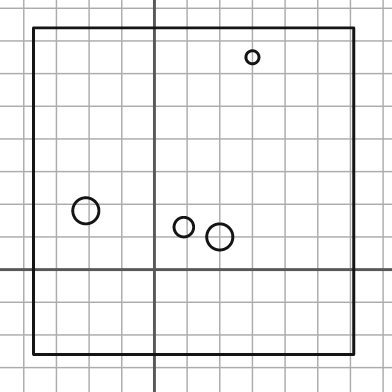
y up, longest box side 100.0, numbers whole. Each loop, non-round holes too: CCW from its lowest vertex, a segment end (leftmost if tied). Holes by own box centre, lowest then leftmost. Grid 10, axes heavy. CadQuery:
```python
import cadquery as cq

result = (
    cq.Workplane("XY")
    .moveTo(-37.0, -26.0)
    .lineTo(61.0, -26.0)
    .lineTo(61.0, 74.0)
    .lineTo(-37.0, 74.0)
    .close()
    .moveTo(20.0, 10.0)
    .circle(4.0)
    .moveTo(9.0, 13.0)
    .circle(3.0)
    .moveTo(-21.0, 18.0)
    .circle(4.0)
    .moveTo(30.0, 65.0)
    .circle(2.0)
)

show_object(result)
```